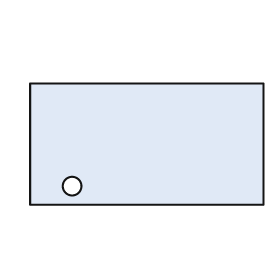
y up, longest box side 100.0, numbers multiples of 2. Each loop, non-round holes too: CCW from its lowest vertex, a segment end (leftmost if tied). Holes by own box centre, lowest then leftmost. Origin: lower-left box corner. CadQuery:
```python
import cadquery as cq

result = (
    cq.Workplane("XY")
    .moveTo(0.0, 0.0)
    .lineTo(100.0, 0.0)
    .lineTo(100.0, 52.0)
    .lineTo(0.0, 52.0)
    .close()
    .moveTo(18.0, 8.0)
    .circle(4.0)
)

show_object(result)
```